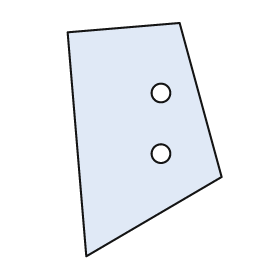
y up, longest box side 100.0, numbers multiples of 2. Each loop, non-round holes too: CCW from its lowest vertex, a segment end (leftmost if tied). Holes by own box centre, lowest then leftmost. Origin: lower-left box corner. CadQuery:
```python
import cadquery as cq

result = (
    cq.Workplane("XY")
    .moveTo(8.0, 0.0)
    .lineTo(66.0, 34.0)
    .lineTo(48.0, 100.0)
    .lineTo(0.0, 96.0)
    .close()
    .moveTo(40.0, 44.0)
    .circle(4.0)
    .moveTo(40.0, 70.0)
    .circle(4.0)
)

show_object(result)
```